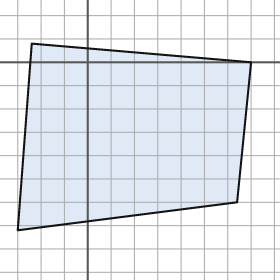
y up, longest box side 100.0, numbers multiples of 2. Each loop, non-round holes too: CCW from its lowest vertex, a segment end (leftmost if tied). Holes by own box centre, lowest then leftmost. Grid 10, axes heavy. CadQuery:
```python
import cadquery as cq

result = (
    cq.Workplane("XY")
    .moveTo(-30.0, -72.0)
    .lineTo(64.0, -60.0)
    .lineTo(70.0, 0.0)
    .lineTo(-24.0, 8.0)
    .close()
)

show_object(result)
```